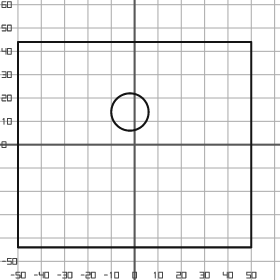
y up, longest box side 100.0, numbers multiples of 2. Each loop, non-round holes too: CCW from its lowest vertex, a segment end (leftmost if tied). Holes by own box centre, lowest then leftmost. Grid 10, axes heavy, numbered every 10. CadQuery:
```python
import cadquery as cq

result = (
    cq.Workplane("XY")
    .moveTo(-50.0, -44.0)
    .lineTo(50.0, -44.0)
    .lineTo(50.0, 44.0)
    .lineTo(-50.0, 44.0)
    .close()
    .moveTo(-2.0, 14.0)
    .circle(8.0)
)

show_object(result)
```